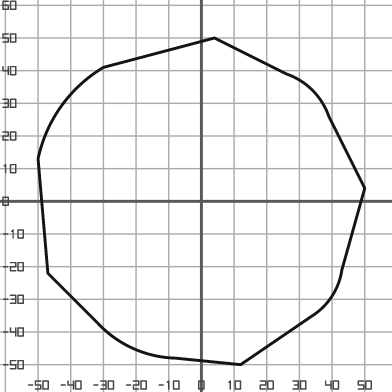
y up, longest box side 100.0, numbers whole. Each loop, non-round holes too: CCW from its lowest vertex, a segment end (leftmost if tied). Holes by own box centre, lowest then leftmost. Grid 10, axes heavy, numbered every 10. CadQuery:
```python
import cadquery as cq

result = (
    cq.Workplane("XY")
    .moveTo(12.0, -50.0)
    .lineTo(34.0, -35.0)
    .threePointArc((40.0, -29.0), (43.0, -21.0))
    .lineTo(50.0, 4.0)
    .lineTo(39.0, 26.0)
    .threePointArc((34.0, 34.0), (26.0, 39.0))
    .lineTo(4.0, 50.0)
    .lineTo(-30.0, 41.0)
    .threePointArc((-43.0, 29.0), (-50.0, 13.0))
    .lineTo(-47.0, -22.0)
    .lineTo(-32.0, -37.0)
    .threePointArc((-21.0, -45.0), (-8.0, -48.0))
    .close()
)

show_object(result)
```